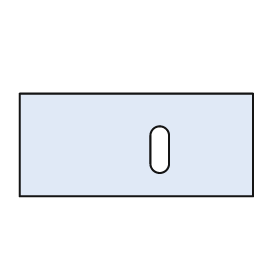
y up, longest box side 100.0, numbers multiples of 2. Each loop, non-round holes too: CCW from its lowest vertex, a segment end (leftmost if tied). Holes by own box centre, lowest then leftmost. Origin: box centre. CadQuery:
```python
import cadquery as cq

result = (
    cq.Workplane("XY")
    .moveTo(-50.0, -22.0)
    .lineTo(50.0, -22.0)
    .lineTo(50.0, 22.0)
    .lineTo(-50.0, 22.0)
    .close()
    .moveTo(6.0, -8.0)
    .threePointArc((10.0, -12.0), (14.0, -8.0))
    .lineTo(14.0, 4.0)
    .threePointArc((10.0, 8.0), (6.0, 4.0))
    .close()
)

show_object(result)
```